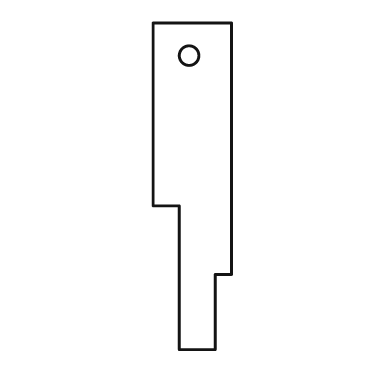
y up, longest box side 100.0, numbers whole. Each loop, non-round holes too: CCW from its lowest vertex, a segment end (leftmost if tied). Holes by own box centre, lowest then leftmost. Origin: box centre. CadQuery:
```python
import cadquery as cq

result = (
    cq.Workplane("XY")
    .moveTo(-4.0, -50.0)
    .lineTo(7.0, -50.0)
    .lineTo(7.0, -27.0)
    .lineTo(12.0, -27.0)
    .lineTo(12.0, 50.0)
    .lineTo(-12.0, 50.0)
    .lineTo(-12.0, -6.0)
    .lineTo(-4.0, -6.0)
    .close()
    .moveTo(-1.0, 40.0)
    .circle(3.0)
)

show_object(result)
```